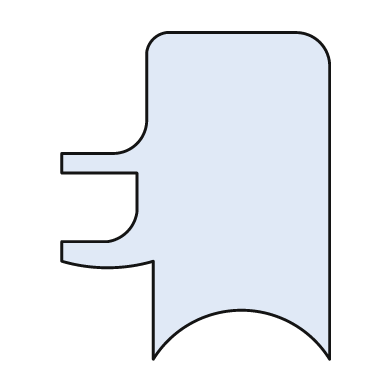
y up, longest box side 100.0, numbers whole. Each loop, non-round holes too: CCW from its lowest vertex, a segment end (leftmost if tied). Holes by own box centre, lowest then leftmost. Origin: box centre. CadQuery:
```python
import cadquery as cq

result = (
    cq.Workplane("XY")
    .moveTo(-13.0, -50.0)
    .threePointArc((14.0, -35.0), (41.0, -50.0))
    .lineTo(41.0, 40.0)
    .threePointArc((38.0, 47.0), (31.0, 50.0))
    .lineTo(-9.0, 50.0)
    .threePointArc((-13.0, 48.0), (-15.0, 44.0))
    .lineTo(-15.0, 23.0)
    .threePointArc((-18.0, 16.0), (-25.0, 13.0))
    .lineTo(-41.0, 13.0)
    .lineTo(-41.0, 7.0)
    .lineTo(-18.0, 7.0)
    .lineTo(-18.0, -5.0)
    .threePointArc((-21.0, -11.0), (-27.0, -14.0))
    .lineTo(-41.0, -14.0)
    .lineTo(-41.0, -20.0)
    .threePointArc((-27.0, -22.0), (-13.0, -20.0))
    .close()
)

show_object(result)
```